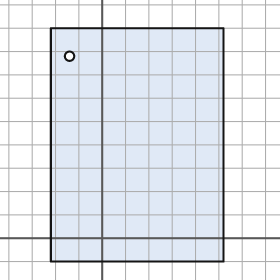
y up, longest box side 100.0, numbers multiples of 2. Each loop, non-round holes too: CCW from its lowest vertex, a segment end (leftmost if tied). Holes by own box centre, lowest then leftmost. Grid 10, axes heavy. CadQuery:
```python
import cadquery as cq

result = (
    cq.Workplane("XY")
    .moveTo(-22.0, -10.0)
    .lineTo(52.0, -10.0)
    .lineTo(52.0, 90.0)
    .lineTo(-22.0, 90.0)
    .close()
    .moveTo(-14.0, 78.0)
    .circle(2.0)
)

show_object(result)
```